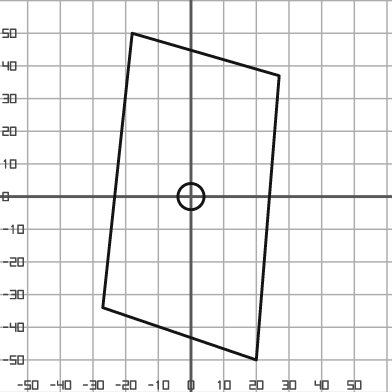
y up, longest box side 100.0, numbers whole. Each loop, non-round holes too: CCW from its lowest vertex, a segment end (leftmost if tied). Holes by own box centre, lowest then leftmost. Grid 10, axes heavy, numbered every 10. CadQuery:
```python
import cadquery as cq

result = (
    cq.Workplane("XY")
    .moveTo(20.0, -50.0)
    .lineTo(27.0, 37.0)
    .lineTo(-18.0, 50.0)
    .lineTo(-27.0, -34.0)
    .close()
    .moveTo(0.0, 0.0)
    .circle(4.0)
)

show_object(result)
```